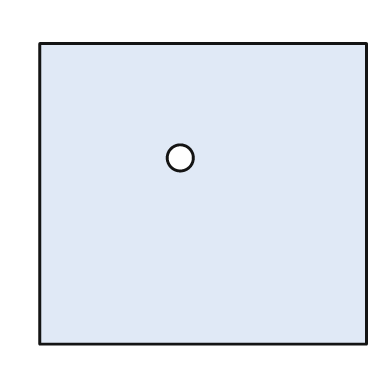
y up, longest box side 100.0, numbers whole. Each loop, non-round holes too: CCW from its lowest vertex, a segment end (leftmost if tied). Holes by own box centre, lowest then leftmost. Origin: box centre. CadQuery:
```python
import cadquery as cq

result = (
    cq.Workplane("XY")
    .moveTo(-50.0, -46.0)
    .lineTo(50.0, -46.0)
    .lineTo(50.0, 46.0)
    .lineTo(-50.0, 46.0)
    .close()
    .moveTo(-7.0, 11.0)
    .circle(4.0)
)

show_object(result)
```